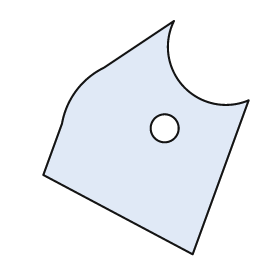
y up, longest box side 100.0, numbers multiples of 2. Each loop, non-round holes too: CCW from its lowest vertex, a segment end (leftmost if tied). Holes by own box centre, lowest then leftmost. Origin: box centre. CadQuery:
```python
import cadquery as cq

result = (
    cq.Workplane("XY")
    .moveTo(20.0, -50.0)
    .lineTo(44.0, 16.0)
    .threePointArc((16.0, 22.0), (12.0, 50.0))
    .lineTo(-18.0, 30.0)
    .threePointArc((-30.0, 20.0), (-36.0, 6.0))
    .lineTo(-44.0, -16.0)
    .close()
    .moveTo(8.0, 4.0)
    .circle(6.0)
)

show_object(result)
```